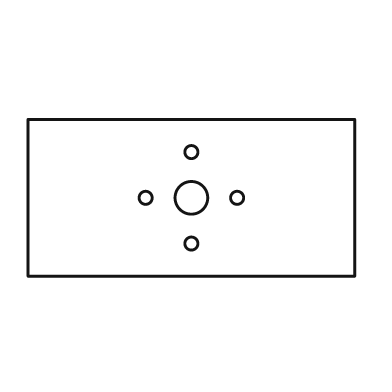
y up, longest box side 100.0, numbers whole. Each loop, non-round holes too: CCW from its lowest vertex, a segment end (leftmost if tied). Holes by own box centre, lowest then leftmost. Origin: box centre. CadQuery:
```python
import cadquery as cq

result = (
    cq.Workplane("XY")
    .moveTo(-50.0, -24.0)
    .lineTo(50.0, -24.0)
    .lineTo(50.0, 24.0)
    .lineTo(-50.0, 24.0)
    .close()
    .moveTo(0.0, -14.0)
    .circle(2.0)
    .moveTo(-14.0, 0.0)
    .circle(2.0)
    .moveTo(0.0, 0.0)
    .circle(5.0)
    .moveTo(14.0, 0.0)
    .circle(2.0)
    .moveTo(0.0, 14.0)
    .circle(2.0)
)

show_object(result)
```